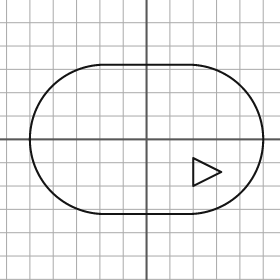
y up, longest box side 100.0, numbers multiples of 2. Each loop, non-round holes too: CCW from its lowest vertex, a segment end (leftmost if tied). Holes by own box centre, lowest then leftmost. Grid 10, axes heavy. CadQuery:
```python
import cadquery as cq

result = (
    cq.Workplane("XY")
    .moveTo(-18.0, -32.0)
    .lineTo(18.0, -32.0)
    .threePointArc((50.0, 0.0), (18.0, 32.0))
    .lineTo(-18.0, 32.0)
    .threePointArc((-50.0, 0.0), (-18.0, -32.0))
    .close()
    .moveTo(20.0, -20.0)
    .lineTo(32.0, -14.0)
    .lineTo(20.0, -8.0)
    .close()
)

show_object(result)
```